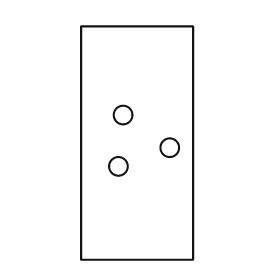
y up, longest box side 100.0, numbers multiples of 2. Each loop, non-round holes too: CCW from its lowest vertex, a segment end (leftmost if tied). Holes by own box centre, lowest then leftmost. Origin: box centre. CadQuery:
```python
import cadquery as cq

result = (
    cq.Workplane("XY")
    .moveTo(-24.0, -50.0)
    .lineTo(24.0, -50.0)
    .lineTo(24.0, 50.0)
    .lineTo(-24.0, 50.0)
    .close()
    .moveTo(-8.0, -10.0)
    .circle(4.0)
    .moveTo(14.0, -2.0)
    .circle(4.0)
    .moveTo(-6.0, 12.0)
    .circle(4.0)
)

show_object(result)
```